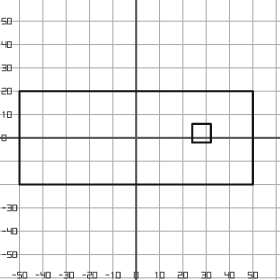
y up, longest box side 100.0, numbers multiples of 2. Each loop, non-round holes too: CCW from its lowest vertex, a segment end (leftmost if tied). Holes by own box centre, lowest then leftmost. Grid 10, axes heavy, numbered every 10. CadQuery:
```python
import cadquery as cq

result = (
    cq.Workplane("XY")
    .moveTo(-50.0, -20.0)
    .lineTo(50.0, -20.0)
    .lineTo(50.0, 20.0)
    .lineTo(-50.0, 20.0)
    .close()
    .moveTo(24.0, -2.0)
    .lineTo(32.0, -2.0)
    .lineTo(32.0, 6.0)
    .lineTo(24.0, 6.0)
    .close()
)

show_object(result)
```